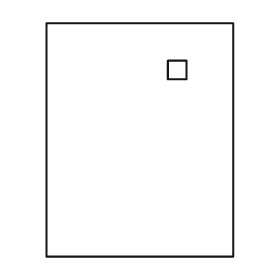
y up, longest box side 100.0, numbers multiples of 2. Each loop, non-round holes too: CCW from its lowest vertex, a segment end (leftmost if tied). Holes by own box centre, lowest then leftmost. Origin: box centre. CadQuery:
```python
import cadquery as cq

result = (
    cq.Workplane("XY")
    .moveTo(-40.0, -50.0)
    .lineTo(40.0, -50.0)
    .lineTo(40.0, 50.0)
    .lineTo(-40.0, 50.0)
    .close()
    .moveTo(12.0, 26.0)
    .lineTo(20.0, 26.0)
    .lineTo(20.0, 34.0)
    .lineTo(12.0, 34.0)
    .close()
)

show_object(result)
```